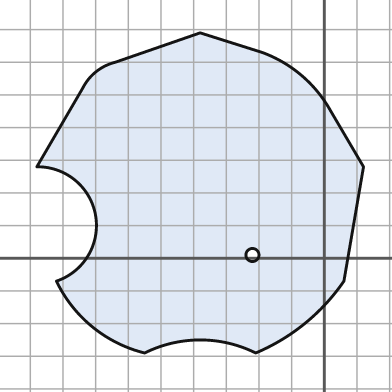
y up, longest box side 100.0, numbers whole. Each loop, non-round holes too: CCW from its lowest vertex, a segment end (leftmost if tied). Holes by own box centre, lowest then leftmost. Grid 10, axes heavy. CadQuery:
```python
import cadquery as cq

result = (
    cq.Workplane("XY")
    .moveTo(-55.0, -29.0)
    .threePointArc((-38.0, -25.0), (-21.0, -29.0))
    .threePointArc((-6.0, -20.0), (6.0, -7.0))
    .lineTo(12.0, 28.0)
    .lineTo(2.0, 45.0)
    .threePointArc((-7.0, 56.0), (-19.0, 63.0))
    .lineTo(-38.0, 69.0)
    .lineTo(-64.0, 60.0)
    .threePointArc((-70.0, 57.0), (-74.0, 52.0))
    .lineTo(-88.0, 28.0)
    .threePointArc((-70.0, 13.0), (-82.0, -7.0))
    .threePointArc((-71.0, -21.0), (-55.0, -29.0))
    .close()
    .moveTo(-22.0, 1.0)
    .circle(2.0)
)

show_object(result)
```